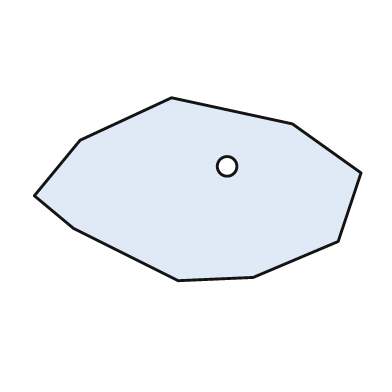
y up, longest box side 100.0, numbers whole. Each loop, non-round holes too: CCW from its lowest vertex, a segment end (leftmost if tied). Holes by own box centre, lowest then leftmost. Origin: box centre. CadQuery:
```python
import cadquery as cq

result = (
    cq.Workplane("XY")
    .moveTo(-6.0, -28.0)
    .lineTo(17.0, -27.0)
    .lineTo(43.0, -16.0)
    .lineTo(50.0, 5.0)
    .lineTo(29.0, 20.0)
    .lineTo(-8.0, 28.0)
    .lineTo(-36.0, 15.0)
    .lineTo(-50.0, -2.0)
    .lineTo(-38.0, -12.0)
    .close()
    .moveTo(9.0, 7.0)
    .circle(3.0)
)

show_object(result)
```